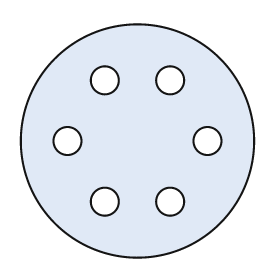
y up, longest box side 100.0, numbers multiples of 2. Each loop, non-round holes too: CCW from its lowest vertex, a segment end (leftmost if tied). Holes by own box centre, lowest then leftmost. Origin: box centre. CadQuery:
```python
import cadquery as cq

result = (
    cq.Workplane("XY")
    .moveTo(0.0, 0.0)
    .circle(50.0)
    .moveTo(-14.0, -26.0)
    .circle(6.0)
    .moveTo(14.0, -26.0)
    .circle(6.0)
    .moveTo(-30.0, 0.0)
    .circle(6.0)
    .moveTo(30.0, 0.0)
    .circle(6.0)
    .moveTo(-14.0, 26.0)
    .circle(6.0)
    .moveTo(14.0, 26.0)
    .circle(6.0)
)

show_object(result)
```